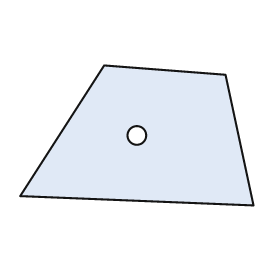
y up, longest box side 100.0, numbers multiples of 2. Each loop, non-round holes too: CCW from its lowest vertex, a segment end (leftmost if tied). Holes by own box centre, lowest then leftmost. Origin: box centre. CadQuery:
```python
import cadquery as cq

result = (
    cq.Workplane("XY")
    .moveTo(50.0, -30.0)
    .lineTo(38.0, 26.0)
    .lineTo(-14.0, 30.0)
    .lineTo(-50.0, -26.0)
    .close()
    .moveTo(0.0, 0.0)
    .circle(4.0)
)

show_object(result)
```